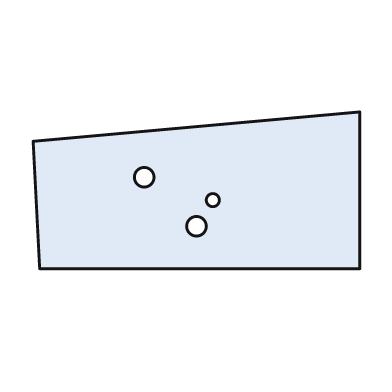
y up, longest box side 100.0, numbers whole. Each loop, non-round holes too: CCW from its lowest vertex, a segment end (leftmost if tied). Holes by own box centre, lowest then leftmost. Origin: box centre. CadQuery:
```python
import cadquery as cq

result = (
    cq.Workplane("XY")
    .moveTo(-48.0, -24.0)
    .lineTo(50.0, -24.0)
    .lineTo(50.0, 24.0)
    .lineTo(-50.0, 15.0)
    .close()
    .moveTo(0.0, -11.0)
    .circle(3.0)
    .moveTo(5.0, -3.0)
    .circle(2.0)
    .moveTo(-16.0, 4.0)
    .circle(3.0)
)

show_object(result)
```